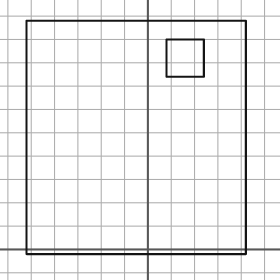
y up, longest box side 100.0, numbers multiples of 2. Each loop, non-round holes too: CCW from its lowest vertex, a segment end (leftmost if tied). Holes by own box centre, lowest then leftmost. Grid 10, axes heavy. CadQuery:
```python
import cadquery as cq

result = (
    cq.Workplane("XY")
    .moveTo(-52.0, -2.0)
    .lineTo(42.0, -2.0)
    .lineTo(42.0, 98.0)
    .lineTo(-52.0, 98.0)
    .close()
    .moveTo(8.0, 74.0)
    .lineTo(24.0, 74.0)
    .lineTo(24.0, 90.0)
    .lineTo(8.0, 90.0)
    .close()
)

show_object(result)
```